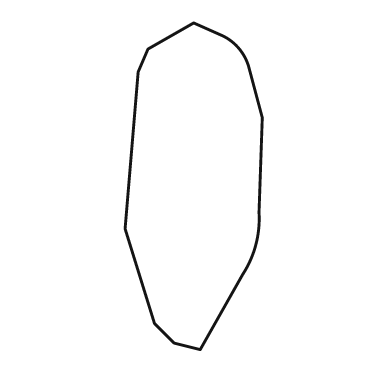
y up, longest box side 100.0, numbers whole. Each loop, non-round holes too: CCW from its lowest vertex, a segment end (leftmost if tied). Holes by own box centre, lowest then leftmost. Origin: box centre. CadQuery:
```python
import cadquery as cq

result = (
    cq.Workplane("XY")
    .moveTo(2.0, -50.0)
    .lineTo(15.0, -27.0)
    .threePointArc((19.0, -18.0), (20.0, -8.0))
    .lineTo(21.0, 21.0)
    .lineTo(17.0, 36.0)
    .threePointArc((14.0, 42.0), (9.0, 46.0))
    .lineTo(0.0, 50.0)
    .lineTo(-14.0, 42.0)
    .lineTo(-17.0, 35.0)
    .lineTo(-21.0, -13.0)
    .lineTo(-12.0, -42.0)
    .lineTo(-6.0, -48.0)
    .close()
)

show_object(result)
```